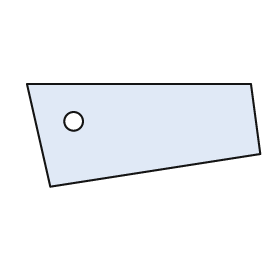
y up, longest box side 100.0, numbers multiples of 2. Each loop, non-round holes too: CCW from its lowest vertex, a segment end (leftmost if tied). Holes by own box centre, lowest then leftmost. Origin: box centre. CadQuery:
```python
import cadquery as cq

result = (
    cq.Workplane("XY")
    .moveTo(-40.0, -22.0)
    .lineTo(50.0, -8.0)
    .lineTo(46.0, 22.0)
    .lineTo(-50.0, 22.0)
    .close()
    .moveTo(-30.0, 6.0)
    .circle(4.0)
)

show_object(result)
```